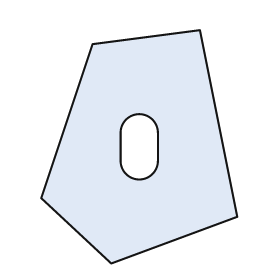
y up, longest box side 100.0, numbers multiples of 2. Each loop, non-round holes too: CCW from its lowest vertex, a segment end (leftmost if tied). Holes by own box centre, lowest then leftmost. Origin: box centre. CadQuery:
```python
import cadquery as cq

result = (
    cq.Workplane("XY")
    .moveTo(-12.0, -50.0)
    .lineTo(42.0, -30.0)
    .lineTo(26.0, 50.0)
    .lineTo(-20.0, 44.0)
    .lineTo(-42.0, -22.0)
    .close()
    .moveTo(-8.0, -6.0)
    .threePointArc((0.0, -14.0), (8.0, -6.0))
    .lineTo(8.0, 6.0)
    .threePointArc((0.0, 14.0), (-8.0, 6.0))
    .close()
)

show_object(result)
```